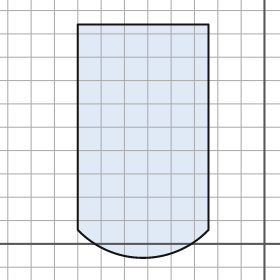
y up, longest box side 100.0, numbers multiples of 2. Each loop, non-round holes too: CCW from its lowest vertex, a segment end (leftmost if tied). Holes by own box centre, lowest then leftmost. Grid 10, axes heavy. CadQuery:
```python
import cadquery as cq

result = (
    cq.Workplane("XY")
    .moveTo(-80.0, 6.0)
    .threePointArc((-52.0, -6.0), (-24.0, 6.0))
    .lineTo(-24.0, 94.0)
    .lineTo(-80.0, 94.0)
    .close()
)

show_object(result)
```